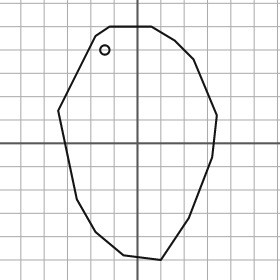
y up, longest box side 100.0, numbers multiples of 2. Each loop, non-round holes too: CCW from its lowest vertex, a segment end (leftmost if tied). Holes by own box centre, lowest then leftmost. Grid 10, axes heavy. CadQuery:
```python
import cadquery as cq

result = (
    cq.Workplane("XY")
    .moveTo(10.0, -50.0)
    .lineTo(22.0, -32.0)
    .lineTo(32.0, -6.0)
    .lineTo(34.0, 12.0)
    .lineTo(24.0, 36.0)
    .lineTo(16.0, 44.0)
    .lineTo(6.0, 50.0)
    .lineTo(-12.0, 50.0)
    .lineTo(-18.0, 46.0)
    .lineTo(-34.0, 14.0)
    .lineTo(-26.0, -24.0)
    .lineTo(-18.0, -38.0)
    .lineTo(-6.0, -48.0)
    .close()
    .moveTo(-14.0, 40.0)
    .circle(2.0)
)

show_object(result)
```